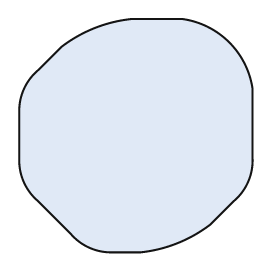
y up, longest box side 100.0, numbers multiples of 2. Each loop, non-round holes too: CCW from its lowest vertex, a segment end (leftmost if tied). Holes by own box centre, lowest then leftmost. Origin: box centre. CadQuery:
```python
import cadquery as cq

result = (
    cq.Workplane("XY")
    .moveTo(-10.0, -50.0)
    .lineTo(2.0, -50.0)
    .threePointArc((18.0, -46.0), (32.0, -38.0))
    .lineTo(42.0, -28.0)
    .threePointArc((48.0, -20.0), (50.0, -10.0))
    .lineTo(50.0, 20.0)
    .threePointArc((40.0, 40.0), (20.0, 50.0))
    .lineTo(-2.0, 50.0)
    .threePointArc((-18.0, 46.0), (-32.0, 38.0))
    .lineTo(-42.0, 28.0)
    .threePointArc((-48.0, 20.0), (-50.0, 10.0))
    .lineTo(-50.0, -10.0)
    .threePointArc((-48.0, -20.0), (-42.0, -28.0))
    .lineTo(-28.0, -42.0)
    .threePointArc((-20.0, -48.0), (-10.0, -50.0))
    .close()
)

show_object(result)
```